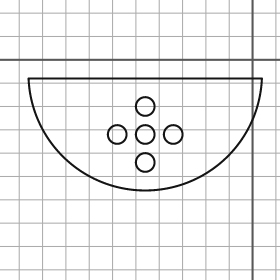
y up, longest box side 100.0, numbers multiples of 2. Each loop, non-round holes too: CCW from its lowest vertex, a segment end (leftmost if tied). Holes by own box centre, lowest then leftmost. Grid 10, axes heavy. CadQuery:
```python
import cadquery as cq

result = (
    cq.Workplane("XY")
    .moveTo(-96.0, -8.0)
    .threePointArc((-46.0, -56.0), (4.0, -8.0))
    .close()
    .moveTo(-46.0, -44.0)
    .circle(4.0)
    .moveTo(-58.0, -32.0)
    .circle(4.0)
    .moveTo(-46.0, -32.0)
    .circle(4.0)
    .moveTo(-34.0, -32.0)
    .circle(4.0)
    .moveTo(-46.0, -20.0)
    .circle(4.0)
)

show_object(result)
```